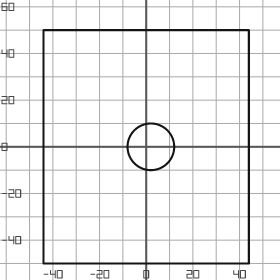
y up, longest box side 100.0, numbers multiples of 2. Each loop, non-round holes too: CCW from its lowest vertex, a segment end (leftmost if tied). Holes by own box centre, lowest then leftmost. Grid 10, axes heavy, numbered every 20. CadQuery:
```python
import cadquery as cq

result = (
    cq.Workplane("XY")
    .moveTo(-44.0, -50.0)
    .lineTo(44.0, -50.0)
    .lineTo(44.0, 50.0)
    .lineTo(-44.0, 50.0)
    .close()
    .moveTo(2.0, 0.0)
    .circle(10.0)
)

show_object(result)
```